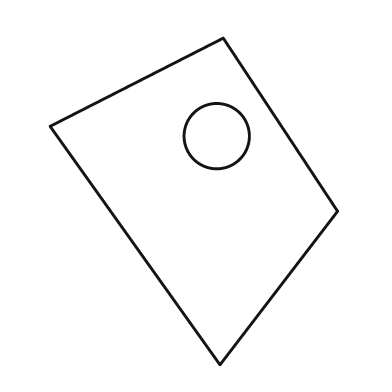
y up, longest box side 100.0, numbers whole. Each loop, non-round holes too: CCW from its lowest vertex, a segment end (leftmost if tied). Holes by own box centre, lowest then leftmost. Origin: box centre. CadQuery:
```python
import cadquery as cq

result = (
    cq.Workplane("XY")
    .moveTo(8.0, -50.0)
    .lineTo(44.0, -3.0)
    .lineTo(9.0, 50.0)
    .lineTo(-44.0, 23.0)
    .close()
    .moveTo(7.0, 20.0)
    .circle(10.0)
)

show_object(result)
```